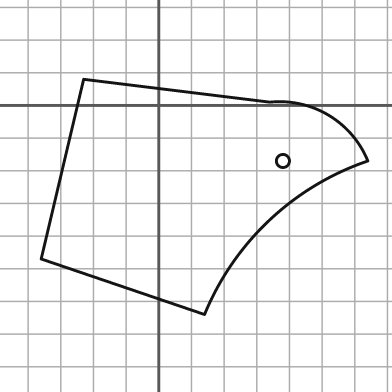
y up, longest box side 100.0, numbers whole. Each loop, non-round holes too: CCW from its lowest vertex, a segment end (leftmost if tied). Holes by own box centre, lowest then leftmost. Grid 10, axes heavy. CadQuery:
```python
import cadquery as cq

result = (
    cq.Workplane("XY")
    .moveTo(14.0, -64.0)
    .threePointArc((34.0, -35.0), (64.0, -17.0))
    .threePointArc((52.0, -3.0), (34.0, 1.0))
    .lineTo(-23.0, 8.0)
    .lineTo(-36.0, -47.0)
    .close()
    .moveTo(38.0, -17.0)
    .circle(2.0)
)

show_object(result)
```